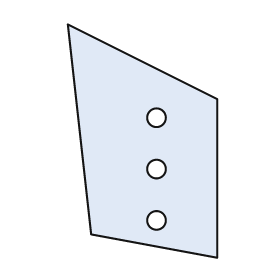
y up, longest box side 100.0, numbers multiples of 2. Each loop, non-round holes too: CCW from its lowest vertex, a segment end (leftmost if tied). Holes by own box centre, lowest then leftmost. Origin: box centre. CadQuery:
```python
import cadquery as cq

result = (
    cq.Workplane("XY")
    .moveTo(32.0, -50.0)
    .lineTo(32.0, 18.0)
    .lineTo(-32.0, 50.0)
    .lineTo(-22.0, -40.0)
    .close()
    .moveTo(6.0, -34.0)
    .circle(4.0)
    .moveTo(6.0, -12.0)
    .circle(4.0)
    .moveTo(6.0, 10.0)
    .circle(4.0)
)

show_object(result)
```